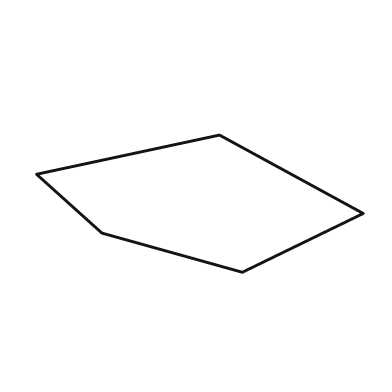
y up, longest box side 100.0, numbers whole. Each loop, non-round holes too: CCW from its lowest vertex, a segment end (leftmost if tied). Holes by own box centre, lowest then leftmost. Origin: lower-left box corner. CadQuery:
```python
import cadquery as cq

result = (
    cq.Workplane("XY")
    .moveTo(63.0, 0.0)
    .lineTo(100.0, 18.0)
    .lineTo(56.0, 42.0)
    .lineTo(0.0, 30.0)
    .lineTo(20.0, 12.0)
    .close()
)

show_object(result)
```